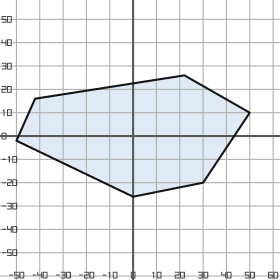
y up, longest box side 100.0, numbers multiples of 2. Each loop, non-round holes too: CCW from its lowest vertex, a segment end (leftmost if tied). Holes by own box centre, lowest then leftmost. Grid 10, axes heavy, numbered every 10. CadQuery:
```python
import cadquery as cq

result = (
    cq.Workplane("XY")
    .moveTo(0.0, -26.0)
    .lineTo(30.0, -20.0)
    .lineTo(50.0, 10.0)
    .lineTo(22.0, 26.0)
    .lineTo(-42.0, 16.0)
    .lineTo(-50.0, -2.0)
    .close()
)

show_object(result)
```